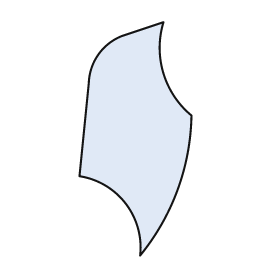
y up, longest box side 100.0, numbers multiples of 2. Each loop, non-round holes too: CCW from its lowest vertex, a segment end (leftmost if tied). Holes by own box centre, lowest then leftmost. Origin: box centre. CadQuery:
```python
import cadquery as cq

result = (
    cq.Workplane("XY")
    .moveTo(2.0, -50.0)
    .threePointArc((18.0, -22.0), (24.0, 10.0))
    .threePointArc((12.0, 28.0), (12.0, 50.0))
    .lineTo(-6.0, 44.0)
    .threePointArc((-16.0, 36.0), (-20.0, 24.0))
    .lineTo(-24.0, -16.0)
    .threePointArc((-4.0, -28.0), (2.0, -50.0))
    .close()
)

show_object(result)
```